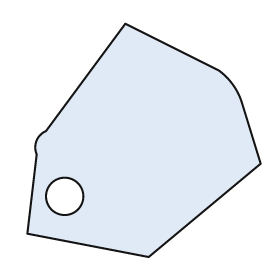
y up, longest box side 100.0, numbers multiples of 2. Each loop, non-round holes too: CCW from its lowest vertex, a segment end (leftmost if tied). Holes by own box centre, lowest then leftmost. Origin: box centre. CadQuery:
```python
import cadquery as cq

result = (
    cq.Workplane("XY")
    .moveTo(2.0, -50.0)
    .lineTo(50.0, -10.0)
    .lineTo(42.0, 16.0)
    .threePointArc((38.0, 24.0), (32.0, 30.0))
    .lineTo(-8.0, 50.0)
    .lineTo(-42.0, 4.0)
    .threePointArc((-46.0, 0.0), (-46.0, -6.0))
    .lineTo(-50.0, -40.0)
    .close()
    .moveTo(-34.0, -24.0)
    .circle(8.0)
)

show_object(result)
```